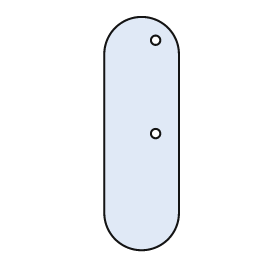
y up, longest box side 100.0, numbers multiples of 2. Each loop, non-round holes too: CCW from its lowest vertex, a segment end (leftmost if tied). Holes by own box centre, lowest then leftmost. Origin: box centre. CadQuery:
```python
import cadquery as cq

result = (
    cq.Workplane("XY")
    .moveTo(-16.0, -34.0)
    .threePointArc((0.0, -50.0), (16.0, -34.0))
    .lineTo(16.0, 34.0)
    .threePointArc((0.0, 50.0), (-16.0, 34.0))
    .close()
    .moveTo(6.0, 0.0)
    .circle(2.0)
    .moveTo(6.0, 40.0)
    .circle(2.0)
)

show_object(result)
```